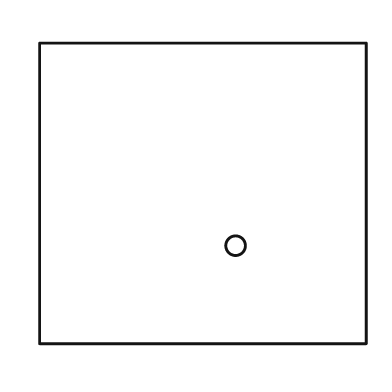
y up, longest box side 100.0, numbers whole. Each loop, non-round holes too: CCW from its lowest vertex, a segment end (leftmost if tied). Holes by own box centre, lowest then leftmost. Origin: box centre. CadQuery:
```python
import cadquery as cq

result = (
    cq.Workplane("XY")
    .moveTo(-50.0, -46.0)
    .lineTo(50.0, -46.0)
    .lineTo(50.0, 46.0)
    .lineTo(-50.0, 46.0)
    .close()
    .moveTo(10.0, -16.0)
    .circle(3.0)
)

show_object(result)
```